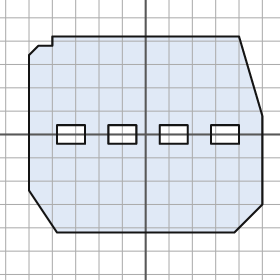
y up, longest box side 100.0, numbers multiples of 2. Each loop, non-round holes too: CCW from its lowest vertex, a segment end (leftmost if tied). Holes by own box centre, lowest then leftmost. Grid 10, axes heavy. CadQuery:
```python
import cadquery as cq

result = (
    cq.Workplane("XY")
    .moveTo(-38.0, -42.0)
    .lineTo(38.0, -42.0)
    .lineTo(50.0, -30.0)
    .lineTo(50.0, 8.0)
    .lineTo(40.0, 42.0)
    .lineTo(-40.0, 42.0)
    .lineTo(-40.0, 38.0)
    .lineTo(-46.0, 38.0)
    .lineTo(-50.0, 34.0)
    .lineTo(-50.0, -24.0)
    .close()
    .moveTo(-38.0, -4.0)
    .lineTo(-26.0, -4.0)
    .lineTo(-26.0, 4.0)
    .lineTo(-38.0, 4.0)
    .close()
    .moveTo(-16.0, -4.0)
    .lineTo(-4.0, -4.0)
    .lineTo(-4.0, 4.0)
    .lineTo(-16.0, 4.0)
    .close()
    .moveTo(6.0, -4.0)
    .lineTo(18.0, -4.0)
    .lineTo(18.0, 4.0)
    .lineTo(6.0, 4.0)
    .close()
    .moveTo(28.0, -4.0)
    .lineTo(40.0, -4.0)
    .lineTo(40.0, 4.0)
    .lineTo(28.0, 4.0)
    .close()
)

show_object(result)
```